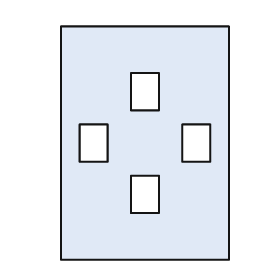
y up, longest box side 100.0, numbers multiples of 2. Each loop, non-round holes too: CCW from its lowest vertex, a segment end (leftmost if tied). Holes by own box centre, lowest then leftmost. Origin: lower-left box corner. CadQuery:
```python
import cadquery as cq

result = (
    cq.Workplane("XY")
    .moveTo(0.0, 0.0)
    .lineTo(72.0, 0.0)
    .lineTo(72.0, 100.0)
    .lineTo(0.0, 100.0)
    .close()
    .moveTo(30.0, 20.0)
    .lineTo(42.0, 20.0)
    .lineTo(42.0, 36.0)
    .lineTo(30.0, 36.0)
    .close()
    .moveTo(8.0, 42.0)
    .lineTo(20.0, 42.0)
    .lineTo(20.0, 58.0)
    .lineTo(8.0, 58.0)
    .close()
    .moveTo(52.0, 42.0)
    .lineTo(64.0, 42.0)
    .lineTo(64.0, 58.0)
    .lineTo(52.0, 58.0)
    .close()
    .moveTo(30.0, 64.0)
    .lineTo(42.0, 64.0)
    .lineTo(42.0, 80.0)
    .lineTo(30.0, 80.0)
    .close()
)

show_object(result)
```